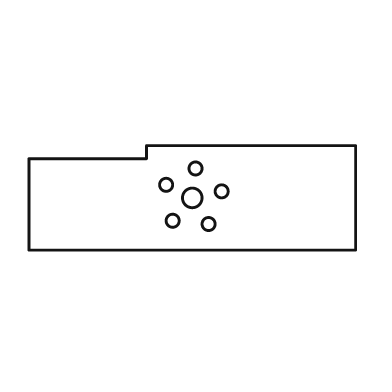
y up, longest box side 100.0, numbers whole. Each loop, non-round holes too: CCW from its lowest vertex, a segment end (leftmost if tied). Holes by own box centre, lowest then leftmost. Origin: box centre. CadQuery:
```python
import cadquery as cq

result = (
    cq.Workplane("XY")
    .moveTo(-50.0, -16.0)
    .lineTo(50.0, -16.0)
    .lineTo(50.0, 16.0)
    .lineTo(-14.0, 16.0)
    .lineTo(-14.0, 12.0)
    .lineTo(-50.0, 12.0)
    .close()
    .moveTo(5.0, -8.0)
    .circle(2.0)
    .moveTo(-6.0, -7.0)
    .circle(2.0)
    .moveTo(0.0, 0.0)
    .circle(3.0)
    .moveTo(9.0, 2.0)
    .circle(2.0)
    .moveTo(-8.0, 4.0)
    .circle(2.0)
    .moveTo(1.0, 9.0)
    .circle(2.0)
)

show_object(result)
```